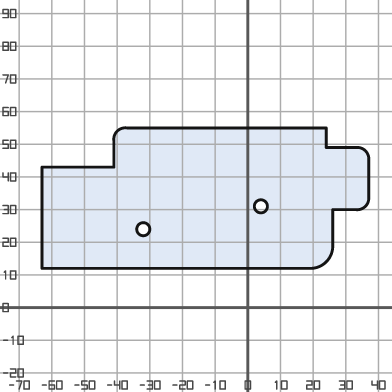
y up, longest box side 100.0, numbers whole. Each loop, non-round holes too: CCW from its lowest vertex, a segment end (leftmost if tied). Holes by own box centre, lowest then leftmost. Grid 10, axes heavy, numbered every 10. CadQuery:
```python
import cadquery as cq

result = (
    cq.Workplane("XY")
    .moveTo(-63.0, 12.0)
    .lineTo(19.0, 12.0)
    .threePointArc((24.0, 14.0), (26.0, 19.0))
    .lineTo(26.0, 30.0)
    .lineTo(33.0, 30.0)
    .threePointArc((36.0, 31.0), (37.0, 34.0))
    .lineTo(37.0, 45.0)
    .threePointArc((36.0, 48.0), (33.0, 49.0))
    .lineTo(24.0, 49.0)
    .lineTo(24.0, 55.0)
    .lineTo(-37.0, 55.0)
    .threePointArc((-40.0, 54.0), (-41.0, 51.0))
    .lineTo(-41.0, 43.0)
    .lineTo(-63.0, 43.0)
    .close()
    .moveTo(-32.0, 24.0)
    .circle(2.0)
    .moveTo(4.0, 31.0)
    .circle(2.0)
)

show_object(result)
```